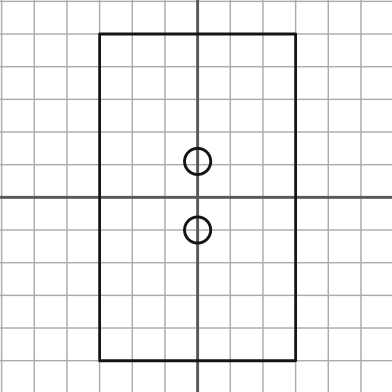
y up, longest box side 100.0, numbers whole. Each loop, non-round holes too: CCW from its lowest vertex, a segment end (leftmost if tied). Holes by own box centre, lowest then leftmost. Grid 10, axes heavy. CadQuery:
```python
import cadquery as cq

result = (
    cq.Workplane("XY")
    .moveTo(-30.0, -50.0)
    .lineTo(30.0, -50.0)
    .lineTo(30.0, 50.0)
    .lineTo(-30.0, 50.0)
    .close()
    .moveTo(0.0, -10.0)
    .circle(4.0)
    .moveTo(0.0, 11.0)
    .circle(4.0)
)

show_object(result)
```